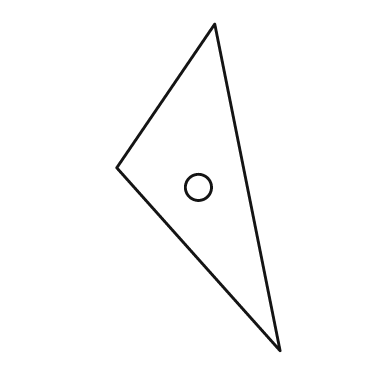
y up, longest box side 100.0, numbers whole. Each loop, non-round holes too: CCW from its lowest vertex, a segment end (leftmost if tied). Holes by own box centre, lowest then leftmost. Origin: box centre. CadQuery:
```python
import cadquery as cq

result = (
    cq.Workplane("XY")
    .moveTo(25.0, -50.0)
    .lineTo(5.0, 50.0)
    .lineTo(-25.0, 6.0)
    .close()
    .moveTo(0.0, 0.0)
    .circle(4.0)
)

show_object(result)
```